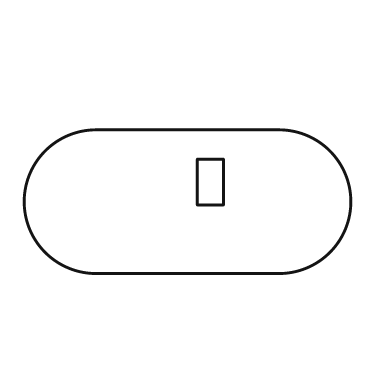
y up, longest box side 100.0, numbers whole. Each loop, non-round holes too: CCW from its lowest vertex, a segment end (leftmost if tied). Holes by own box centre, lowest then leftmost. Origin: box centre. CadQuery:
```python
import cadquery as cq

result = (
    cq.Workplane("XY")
    .moveTo(-28.0, -22.0)
    .lineTo(28.0, -22.0)
    .threePointArc((50.0, 0.0), (28.0, 22.0))
    .lineTo(-28.0, 22.0)
    .threePointArc((-50.0, 0.0), (-28.0, -22.0))
    .close()
    .moveTo(3.0, -1.0)
    .lineTo(11.0, -1.0)
    .lineTo(11.0, 13.0)
    .lineTo(3.0, 13.0)
    .close()
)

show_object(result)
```